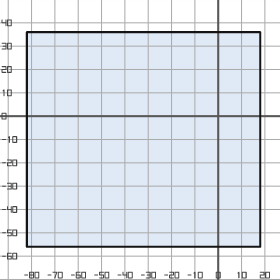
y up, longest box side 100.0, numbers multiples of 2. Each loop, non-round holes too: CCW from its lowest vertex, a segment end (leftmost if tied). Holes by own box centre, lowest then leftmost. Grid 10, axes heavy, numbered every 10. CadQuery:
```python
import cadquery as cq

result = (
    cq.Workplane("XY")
    .moveTo(-82.0, -56.0)
    .lineTo(18.0, -56.0)
    .lineTo(18.0, 36.0)
    .lineTo(-82.0, 36.0)
    .close()
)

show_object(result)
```